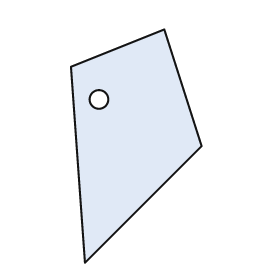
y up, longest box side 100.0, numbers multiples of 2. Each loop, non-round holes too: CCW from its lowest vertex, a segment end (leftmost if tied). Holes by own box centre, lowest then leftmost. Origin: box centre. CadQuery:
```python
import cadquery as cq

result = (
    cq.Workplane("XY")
    .moveTo(-22.0, -50.0)
    .lineTo(28.0, 0.0)
    .lineTo(12.0, 50.0)
    .lineTo(-28.0, 34.0)
    .close()
    .moveTo(-16.0, 20.0)
    .circle(4.0)
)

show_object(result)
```